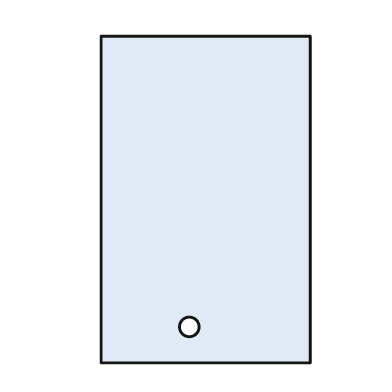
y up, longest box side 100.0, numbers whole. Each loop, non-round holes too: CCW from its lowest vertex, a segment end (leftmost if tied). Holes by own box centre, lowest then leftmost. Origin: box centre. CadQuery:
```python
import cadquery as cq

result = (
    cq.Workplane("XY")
    .moveTo(-32.0, -50.0)
    .lineTo(32.0, -50.0)
    .lineTo(32.0, 50.0)
    .lineTo(-32.0, 50.0)
    .close()
    .moveTo(-5.0, -39.0)
    .circle(3.0)
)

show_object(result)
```